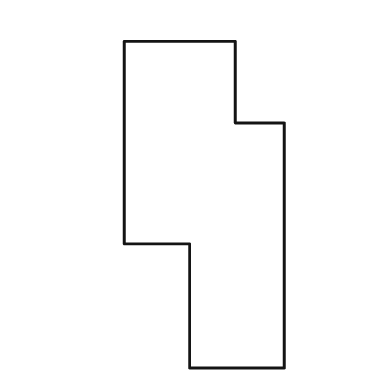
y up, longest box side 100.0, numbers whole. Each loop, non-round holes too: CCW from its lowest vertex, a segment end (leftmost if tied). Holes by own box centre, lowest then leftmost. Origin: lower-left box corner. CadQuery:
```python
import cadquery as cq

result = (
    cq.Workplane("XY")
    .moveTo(20.0, 0.0)
    .lineTo(49.0, 0.0)
    .lineTo(49.0, 75.0)
    .lineTo(34.0, 75.0)
    .lineTo(34.0, 100.0)
    .lineTo(0.0, 100.0)
    .lineTo(0.0, 38.0)
    .lineTo(20.0, 38.0)
    .close()
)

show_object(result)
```